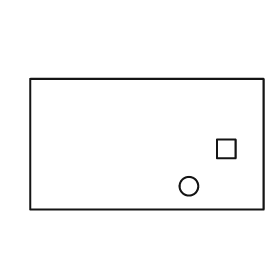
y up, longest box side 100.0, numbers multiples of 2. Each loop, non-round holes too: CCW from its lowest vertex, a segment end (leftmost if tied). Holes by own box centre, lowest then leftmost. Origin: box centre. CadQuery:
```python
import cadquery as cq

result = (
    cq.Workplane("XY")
    .moveTo(-50.0, -28.0)
    .lineTo(50.0, -28.0)
    .lineTo(50.0, 28.0)
    .lineTo(-50.0, 28.0)
    .close()
    .moveTo(18.0, -18.0)
    .circle(4.0)
    .moveTo(30.0, -6.0)
    .lineTo(38.0, -6.0)
    .lineTo(38.0, 2.0)
    .lineTo(30.0, 2.0)
    .close()
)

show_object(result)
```